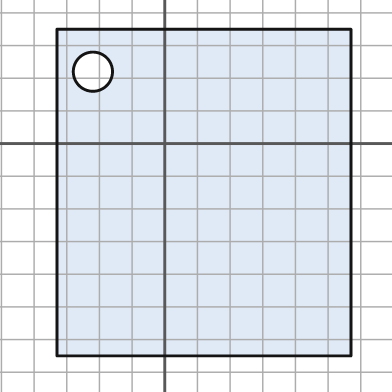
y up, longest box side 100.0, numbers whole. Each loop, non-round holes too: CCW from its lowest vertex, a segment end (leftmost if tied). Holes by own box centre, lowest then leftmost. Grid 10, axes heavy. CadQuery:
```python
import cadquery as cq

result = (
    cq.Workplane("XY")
    .moveTo(-33.0, -65.0)
    .lineTo(57.0, -65.0)
    .lineTo(57.0, 35.0)
    .lineTo(-33.0, 35.0)
    .close()
    .moveTo(-22.0, 22.0)
    .circle(6.0)
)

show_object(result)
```